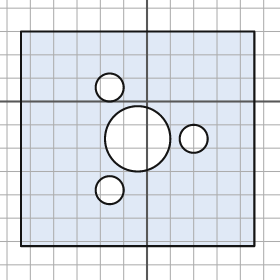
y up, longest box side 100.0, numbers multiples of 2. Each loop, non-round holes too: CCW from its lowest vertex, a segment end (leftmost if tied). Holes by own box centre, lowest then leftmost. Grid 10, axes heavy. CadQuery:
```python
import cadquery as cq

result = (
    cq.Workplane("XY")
    .moveTo(-54.0, -62.0)
    .lineTo(46.0, -62.0)
    .lineTo(46.0, 30.0)
    .lineTo(-54.0, 30.0)
    .close()
    .moveTo(-16.0, -38.0)
    .circle(6.0)
    .moveTo(-4.0, -16.0)
    .circle(14.0)
    .moveTo(20.0, -16.0)
    .circle(6.0)
    .moveTo(-16.0, 6.0)
    .circle(6.0)
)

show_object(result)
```